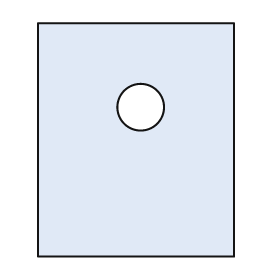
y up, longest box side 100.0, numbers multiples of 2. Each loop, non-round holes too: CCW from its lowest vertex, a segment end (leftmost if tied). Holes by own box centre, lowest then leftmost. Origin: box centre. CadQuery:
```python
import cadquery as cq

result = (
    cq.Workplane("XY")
    .moveTo(-42.0, -50.0)
    .lineTo(42.0, -50.0)
    .lineTo(42.0, 50.0)
    .lineTo(-42.0, 50.0)
    .close()
    .moveTo(2.0, 14.0)
    .circle(10.0)
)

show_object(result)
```